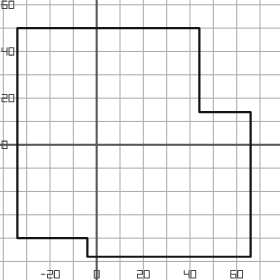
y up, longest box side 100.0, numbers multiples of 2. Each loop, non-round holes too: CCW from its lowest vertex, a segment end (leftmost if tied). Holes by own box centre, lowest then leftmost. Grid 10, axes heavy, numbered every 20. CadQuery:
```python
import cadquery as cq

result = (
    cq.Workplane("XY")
    .moveTo(-4.0, -48.0)
    .lineTo(66.0, -48.0)
    .lineTo(66.0, 14.0)
    .lineTo(44.0, 14.0)
    .lineTo(44.0, 50.0)
    .lineTo(-34.0, 50.0)
    .lineTo(-34.0, -40.0)
    .lineTo(-4.0, -40.0)
    .close()
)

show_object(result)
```